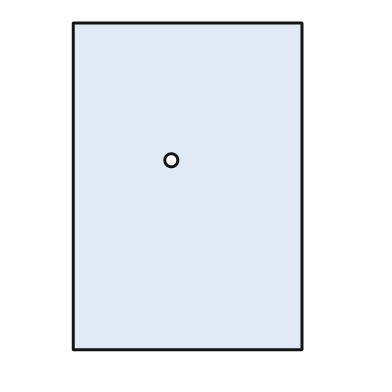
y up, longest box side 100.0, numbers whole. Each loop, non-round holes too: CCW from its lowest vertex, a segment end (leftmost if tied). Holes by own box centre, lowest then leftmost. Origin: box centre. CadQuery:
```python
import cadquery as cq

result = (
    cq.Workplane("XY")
    .moveTo(-35.0, -50.0)
    .lineTo(35.0, -50.0)
    .lineTo(35.0, 50.0)
    .lineTo(-35.0, 50.0)
    .close()
    .moveTo(-5.0, 8.0)
    .circle(2.0)
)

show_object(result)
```